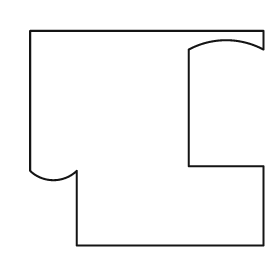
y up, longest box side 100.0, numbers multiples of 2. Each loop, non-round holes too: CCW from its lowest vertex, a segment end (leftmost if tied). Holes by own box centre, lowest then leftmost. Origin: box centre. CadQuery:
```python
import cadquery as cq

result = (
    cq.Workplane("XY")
    .moveTo(-30.0, -46.0)
    .lineTo(50.0, -46.0)
    .lineTo(50.0, -12.0)
    .lineTo(18.0, -12.0)
    .lineTo(18.0, 38.0)
    .threePointArc((34.0, 42.0), (50.0, 38.0))
    .lineTo(50.0, 46.0)
    .lineTo(-50.0, 46.0)
    .lineTo(-50.0, -14.0)
    .threePointArc((-40.0, -18.0), (-30.0, -14.0))
    .close()
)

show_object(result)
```